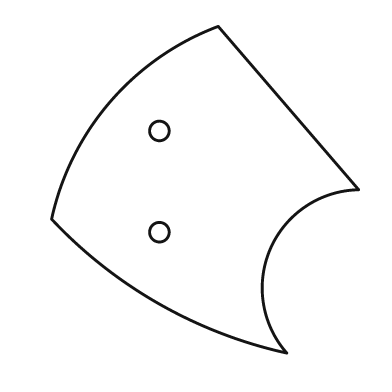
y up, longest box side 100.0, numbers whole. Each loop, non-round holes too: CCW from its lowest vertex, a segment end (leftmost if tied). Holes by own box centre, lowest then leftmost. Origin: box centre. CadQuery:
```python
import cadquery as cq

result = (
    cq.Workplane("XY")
    .moveTo(25.0, -50.0)
    .threePointArc((20.0, -18.0), (47.0, 0.0))
    .lineTo(4.0, 50.0)
    .threePointArc((-29.0, 27.0), (-47.0, -9.0))
    .threePointArc((-14.0, -35.0), (25.0, -50.0))
    .close()
    .moveTo(-14.0, -13.0)
    .circle(3.0)
    .moveTo(-14.0, 18.0)
    .circle(3.0)
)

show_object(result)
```